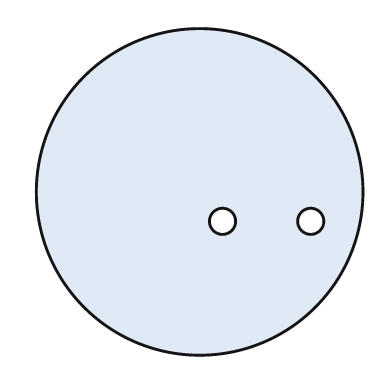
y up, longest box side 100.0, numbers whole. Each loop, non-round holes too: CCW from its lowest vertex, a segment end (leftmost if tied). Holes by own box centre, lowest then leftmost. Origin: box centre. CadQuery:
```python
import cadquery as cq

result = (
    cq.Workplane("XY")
    .moveTo(0.0, 0.0)
    .circle(50.0)
    .moveTo(7.0, -9.0)
    .circle(4.0)
    .moveTo(34.0, -9.0)
    .circle(4.0)
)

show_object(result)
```